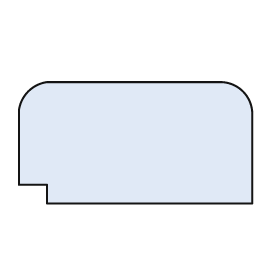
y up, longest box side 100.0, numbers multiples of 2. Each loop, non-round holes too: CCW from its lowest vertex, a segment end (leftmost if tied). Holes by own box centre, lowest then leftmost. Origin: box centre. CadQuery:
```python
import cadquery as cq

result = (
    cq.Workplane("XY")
    .moveTo(-38.0, -26.0)
    .lineTo(50.0, -26.0)
    .lineTo(50.0, 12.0)
    .threePointArc((46.0, 22.0), (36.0, 26.0))
    .lineTo(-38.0, 26.0)
    .threePointArc((-46.0, 22.0), (-50.0, 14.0))
    .lineTo(-50.0, -18.0)
    .lineTo(-38.0, -18.0)
    .close()
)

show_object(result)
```